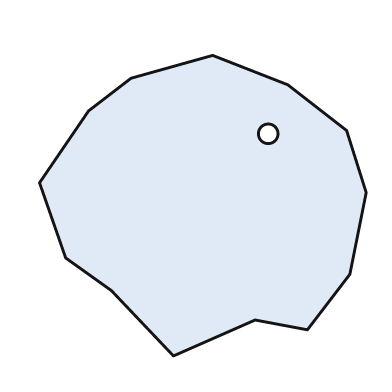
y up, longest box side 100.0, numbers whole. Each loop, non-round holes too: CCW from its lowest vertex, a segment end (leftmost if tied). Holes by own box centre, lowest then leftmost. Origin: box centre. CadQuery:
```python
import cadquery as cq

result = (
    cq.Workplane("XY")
    .moveTo(-9.0, -46.0)
    .lineTo(16.0, -35.0)
    .lineTo(32.0, -38.0)
    .lineTo(45.0, -21.0)
    .lineTo(50.0, 4.0)
    .lineTo(44.0, 23.0)
    .lineTo(26.0, 37.0)
    .lineTo(3.0, 46.0)
    .lineTo(-22.0, 39.0)
    .lineTo(-35.0, 29.0)
    .lineTo(-50.0, 7.0)
    .lineTo(-42.0, -16.0)
    .lineTo(-28.0, -26.0)
    .close()
    .moveTo(20.0, 22.0)
    .circle(3.0)
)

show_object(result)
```